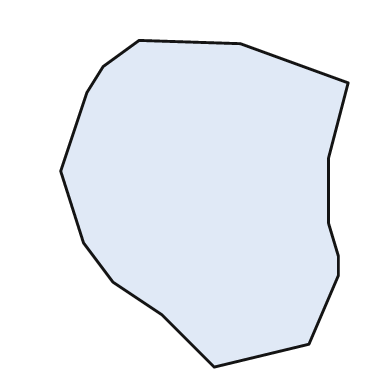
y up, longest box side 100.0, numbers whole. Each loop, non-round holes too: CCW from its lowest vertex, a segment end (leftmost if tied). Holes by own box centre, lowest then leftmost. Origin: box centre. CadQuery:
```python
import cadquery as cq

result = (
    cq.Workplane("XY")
    .moveTo(3.0, -50.0)
    .lineTo(32.0, -43.0)
    .lineTo(41.0, -22.0)
    .lineTo(41.0, -16.0)
    .lineTo(38.0, -6.0)
    .lineTo(38.0, 14.0)
    .lineTo(44.0, 37.0)
    .lineTo(11.0, 49.0)
    .lineTo(-20.0, 50.0)
    .lineTo(-31.0, 42.0)
    .lineTo(-36.0, 34.0)
    .lineTo(-44.0, 10.0)
    .lineTo(-37.0, -12.0)
    .lineTo(-28.0, -24.0)
    .lineTo(-13.0, -34.0)
    .close()
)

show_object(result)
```